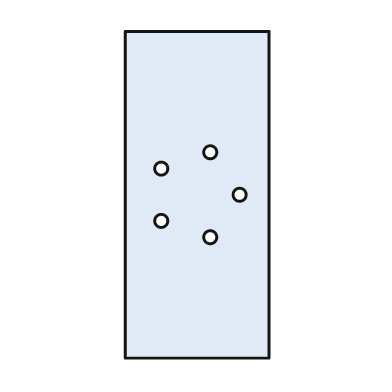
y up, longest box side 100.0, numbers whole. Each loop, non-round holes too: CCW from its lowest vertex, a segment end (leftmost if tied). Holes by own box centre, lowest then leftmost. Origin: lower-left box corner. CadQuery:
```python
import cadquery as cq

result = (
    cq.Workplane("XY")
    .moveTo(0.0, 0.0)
    .lineTo(44.0, 0.0)
    .lineTo(44.0, 100.0)
    .lineTo(0.0, 100.0)
    .close()
    .moveTo(26.0, 37.0)
    .circle(2.0)
    .moveTo(11.0, 42.0)
    .circle(2.0)
    .moveTo(35.0, 50.0)
    .circle(2.0)
    .moveTo(11.0, 58.0)
    .circle(2.0)
    .moveTo(26.0, 63.0)
    .circle(2.0)
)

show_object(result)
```